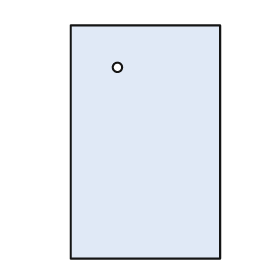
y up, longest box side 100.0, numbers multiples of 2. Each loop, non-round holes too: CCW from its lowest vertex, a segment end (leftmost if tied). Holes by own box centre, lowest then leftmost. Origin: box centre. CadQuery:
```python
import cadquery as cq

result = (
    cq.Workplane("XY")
    .moveTo(-32.0, -50.0)
    .lineTo(32.0, -50.0)
    .lineTo(32.0, 50.0)
    .lineTo(-32.0, 50.0)
    .close()
    .moveTo(-12.0, 32.0)
    .circle(2.0)
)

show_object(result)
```